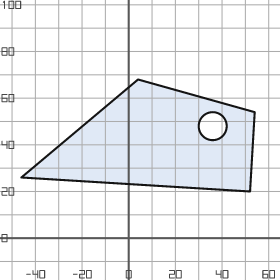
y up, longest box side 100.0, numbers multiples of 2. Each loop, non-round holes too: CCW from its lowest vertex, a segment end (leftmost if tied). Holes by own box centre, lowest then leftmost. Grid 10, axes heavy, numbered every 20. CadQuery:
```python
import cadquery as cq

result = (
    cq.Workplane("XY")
    .moveTo(52.0, 20.0)
    .lineTo(54.0, 54.0)
    .lineTo(4.0, 68.0)
    .lineTo(-46.0, 26.0)
    .close()
    .moveTo(36.0, 48.0)
    .circle(6.0)
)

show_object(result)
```